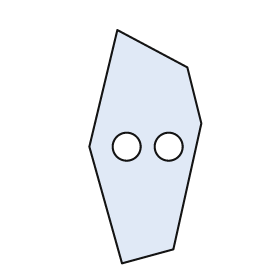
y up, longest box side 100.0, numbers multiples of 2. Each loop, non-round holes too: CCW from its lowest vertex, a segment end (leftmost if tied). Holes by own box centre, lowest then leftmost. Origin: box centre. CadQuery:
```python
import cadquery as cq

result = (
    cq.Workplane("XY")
    .moveTo(-10.0, -50.0)
    .lineTo(12.0, -44.0)
    .lineTo(24.0, 10.0)
    .lineTo(18.0, 34.0)
    .lineTo(-12.0, 50.0)
    .lineTo(-24.0, 0.0)
    .close()
    .moveTo(-8.0, 0.0)
    .circle(6.0)
    .moveTo(10.0, 0.0)
    .circle(6.0)
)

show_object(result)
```